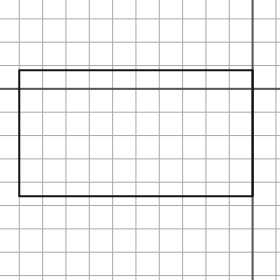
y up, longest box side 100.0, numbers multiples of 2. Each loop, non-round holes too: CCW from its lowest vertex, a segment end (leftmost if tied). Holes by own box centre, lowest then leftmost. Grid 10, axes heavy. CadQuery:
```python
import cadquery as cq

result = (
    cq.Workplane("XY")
    .moveTo(-100.0, -46.0)
    .lineTo(0.0, -46.0)
    .lineTo(0.0, 8.0)
    .lineTo(-100.0, 8.0)
    .close()
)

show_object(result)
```